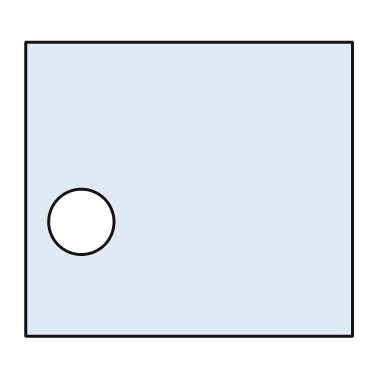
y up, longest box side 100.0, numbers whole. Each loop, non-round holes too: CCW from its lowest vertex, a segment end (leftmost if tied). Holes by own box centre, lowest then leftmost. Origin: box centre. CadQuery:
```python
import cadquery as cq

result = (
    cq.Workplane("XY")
    .moveTo(-50.0, -45.0)
    .lineTo(50.0, -45.0)
    .lineTo(50.0, 45.0)
    .lineTo(-50.0, 45.0)
    .close()
    .moveTo(-33.0, -10.0)
    .circle(10.0)
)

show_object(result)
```